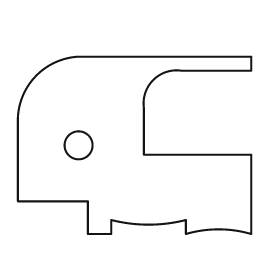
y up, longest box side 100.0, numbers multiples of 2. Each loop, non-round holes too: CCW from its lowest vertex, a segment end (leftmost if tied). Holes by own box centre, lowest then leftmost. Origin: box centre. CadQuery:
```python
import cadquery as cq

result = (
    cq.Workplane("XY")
    .moveTo(-20.0, -38.0)
    .lineTo(-10.0, -38.0)
    .lineTo(-10.0, -32.0)
    .threePointArc((6.0, -34.0), (22.0, -32.0))
    .lineTo(22.0, -38.0)
    .threePointArc((36.0, -36.0), (50.0, -38.0))
    .lineTo(50.0, -4.0)
    .lineTo(4.0, -4.0)
    .lineTo(4.0, 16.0)
    .threePointArc((8.0, 28.0), (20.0, 32.0))
    .lineTo(50.0, 32.0)
    .lineTo(50.0, 38.0)
    .lineTo(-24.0, 38.0)
    .threePointArc((-42.0, 30.0), (-50.0, 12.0))
    .lineTo(-50.0, -24.0)
    .lineTo(-20.0, -24.0)
    .close()
    .moveTo(-24.0, 0.0)
    .circle(6.0)
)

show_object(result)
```